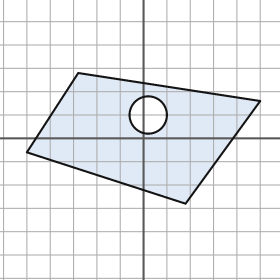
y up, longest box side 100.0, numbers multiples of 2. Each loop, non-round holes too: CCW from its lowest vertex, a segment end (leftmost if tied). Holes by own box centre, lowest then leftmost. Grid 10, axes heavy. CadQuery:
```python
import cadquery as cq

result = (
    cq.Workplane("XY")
    .moveTo(18.0, -28.0)
    .lineTo(50.0, 16.0)
    .lineTo(-28.0, 28.0)
    .lineTo(-50.0, -6.0)
    .close()
    .moveTo(2.0, 10.0)
    .circle(8.0)
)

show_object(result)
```